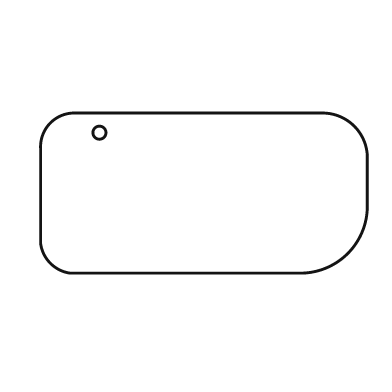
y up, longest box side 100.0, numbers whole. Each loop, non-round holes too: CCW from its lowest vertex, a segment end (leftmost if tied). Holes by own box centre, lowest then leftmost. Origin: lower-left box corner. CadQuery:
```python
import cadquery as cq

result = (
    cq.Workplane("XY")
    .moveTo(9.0, 0.0)
    .lineTo(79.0, 0.0)
    .threePointArc((94.0, 6.0), (100.0, 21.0))
    .lineTo(100.0, 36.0)
    .threePointArc((96.0, 45.0), (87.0, 49.0))
    .lineTo(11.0, 49.0)
    .threePointArc((3.0, 46.0), (0.0, 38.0))
    .lineTo(0.0, 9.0)
    .threePointArc((3.0, 3.0), (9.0, 0.0))
    .close()
    .moveTo(18.0, 43.0)
    .circle(2.0)
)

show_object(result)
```